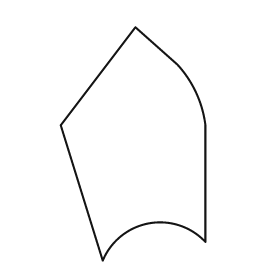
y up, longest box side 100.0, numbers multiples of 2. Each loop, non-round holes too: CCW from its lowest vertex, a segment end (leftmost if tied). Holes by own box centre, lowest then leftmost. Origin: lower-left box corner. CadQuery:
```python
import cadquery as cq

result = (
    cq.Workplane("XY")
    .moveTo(18.0, 0.0)
    .threePointArc((38.0, 16.0), (62.0, 8.0))
    .lineTo(62.0, 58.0)
    .threePointArc((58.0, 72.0), (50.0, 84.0))
    .lineTo(32.0, 100.0)
    .lineTo(0.0, 58.0)
    .close()
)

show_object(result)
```